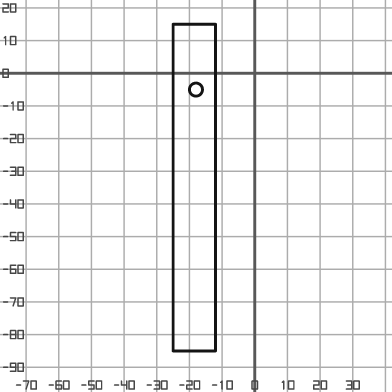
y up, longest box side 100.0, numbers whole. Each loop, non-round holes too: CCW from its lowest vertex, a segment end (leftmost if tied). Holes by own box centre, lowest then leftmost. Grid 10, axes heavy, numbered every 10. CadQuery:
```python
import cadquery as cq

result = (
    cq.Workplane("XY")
    .moveTo(-25.0, -85.0)
    .lineTo(-12.0, -85.0)
    .lineTo(-12.0, 15.0)
    .lineTo(-25.0, 15.0)
    .close()
    .moveTo(-18.0, -5.0)
    .circle(2.0)
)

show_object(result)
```